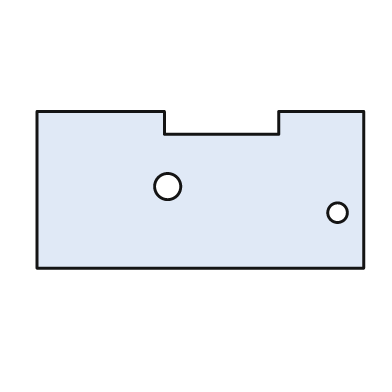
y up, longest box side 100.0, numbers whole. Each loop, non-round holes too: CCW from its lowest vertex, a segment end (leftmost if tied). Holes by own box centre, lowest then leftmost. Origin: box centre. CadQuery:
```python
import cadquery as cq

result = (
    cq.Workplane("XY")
    .moveTo(-50.0, -24.0)
    .lineTo(50.0, -24.0)
    .lineTo(50.0, 24.0)
    .lineTo(24.0, 24.0)
    .lineTo(24.0, 17.0)
    .lineTo(-11.0, 17.0)
    .lineTo(-11.0, 24.0)
    .lineTo(-50.0, 24.0)
    .close()
    .moveTo(42.0, -7.0)
    .circle(3.0)
    .moveTo(-10.0, 1.0)
    .circle(4.0)
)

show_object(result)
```